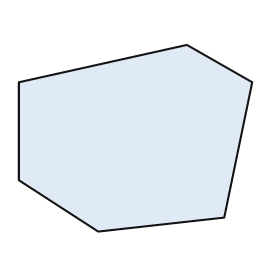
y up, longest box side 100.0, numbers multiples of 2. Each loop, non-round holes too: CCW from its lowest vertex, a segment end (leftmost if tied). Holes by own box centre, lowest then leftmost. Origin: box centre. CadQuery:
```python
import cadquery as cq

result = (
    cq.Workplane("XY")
    .moveTo(-16.0, -40.0)
    .lineTo(38.0, -34.0)
    .lineTo(50.0, 24.0)
    .lineTo(22.0, 40.0)
    .lineTo(-50.0, 24.0)
    .lineTo(-50.0, -18.0)
    .close()
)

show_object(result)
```